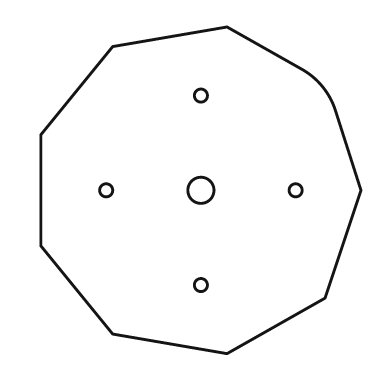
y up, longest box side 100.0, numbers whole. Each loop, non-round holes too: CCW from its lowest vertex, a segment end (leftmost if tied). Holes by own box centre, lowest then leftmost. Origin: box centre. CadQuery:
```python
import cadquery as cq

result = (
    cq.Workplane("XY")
    .moveTo(8.0, -50.0)
    .lineTo(38.0, -33.0)
    .lineTo(49.0, 0.0)
    .lineTo(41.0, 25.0)
    .threePointArc((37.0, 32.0), (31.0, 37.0))
    .lineTo(8.0, 50.0)
    .lineTo(-27.0, 44.0)
    .lineTo(-49.0, 17.0)
    .lineTo(-49.0, -17.0)
    .lineTo(-27.0, -44.0)
    .close()
    .moveTo(0.0, -29.0)
    .circle(2.0)
    .moveTo(-29.0, 0.0)
    .circle(2.0)
    .moveTo(0.0, 0.0)
    .circle(4.0)
    .moveTo(29.0, 0.0)
    .circle(2.0)
    .moveTo(0.0, 29.0)
    .circle(2.0)
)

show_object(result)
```